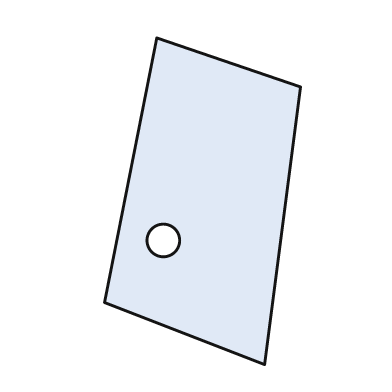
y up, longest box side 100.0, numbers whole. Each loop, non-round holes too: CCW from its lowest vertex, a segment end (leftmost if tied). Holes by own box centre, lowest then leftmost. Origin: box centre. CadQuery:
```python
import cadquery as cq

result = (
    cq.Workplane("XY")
    .moveTo(19.0, -50.0)
    .lineTo(30.0, 35.0)
    .lineTo(-14.0, 50.0)
    .lineTo(-30.0, -31.0)
    .close()
    .moveTo(-12.0, -12.0)
    .circle(5.0)
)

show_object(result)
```